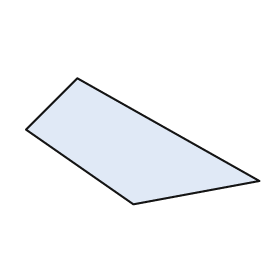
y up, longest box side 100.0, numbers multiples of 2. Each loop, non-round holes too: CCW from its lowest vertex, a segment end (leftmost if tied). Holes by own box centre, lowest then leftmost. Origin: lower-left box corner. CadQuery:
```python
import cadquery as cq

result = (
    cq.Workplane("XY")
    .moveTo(46.0, 0.0)
    .lineTo(100.0, 10.0)
    .lineTo(22.0, 54.0)
    .lineTo(0.0, 32.0)
    .close()
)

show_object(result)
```